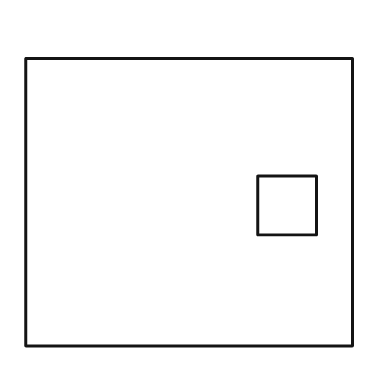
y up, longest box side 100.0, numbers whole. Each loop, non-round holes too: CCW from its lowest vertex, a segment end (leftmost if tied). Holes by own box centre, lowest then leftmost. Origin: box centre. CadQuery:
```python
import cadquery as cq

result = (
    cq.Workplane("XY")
    .moveTo(-50.0, -44.0)
    .lineTo(50.0, -44.0)
    .lineTo(50.0, 44.0)
    .lineTo(-50.0, 44.0)
    .close()
    .moveTo(21.0, -10.0)
    .lineTo(39.0, -10.0)
    .lineTo(39.0, 8.0)
    .lineTo(21.0, 8.0)
    .close()
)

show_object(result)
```